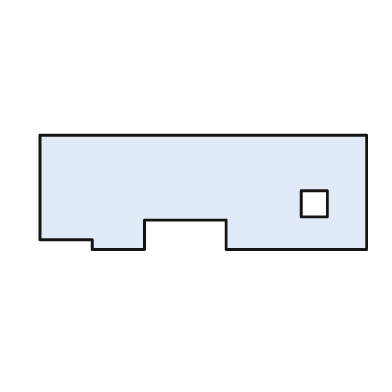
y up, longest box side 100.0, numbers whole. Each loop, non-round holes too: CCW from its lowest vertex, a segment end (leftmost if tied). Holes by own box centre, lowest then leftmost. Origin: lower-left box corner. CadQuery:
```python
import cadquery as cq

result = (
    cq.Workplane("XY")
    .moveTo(16.0, 0.0)
    .lineTo(32.0, 0.0)
    .lineTo(32.0, 9.0)
    .lineTo(57.0, 9.0)
    .lineTo(57.0, 0.0)
    .lineTo(100.0, 0.0)
    .lineTo(100.0, 35.0)
    .lineTo(0.0, 35.0)
    .lineTo(0.0, 3.0)
    .lineTo(16.0, 3.0)
    .close()
    .moveTo(80.0, 10.0)
    .lineTo(88.0, 10.0)
    .lineTo(88.0, 18.0)
    .lineTo(80.0, 18.0)
    .close()
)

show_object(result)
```